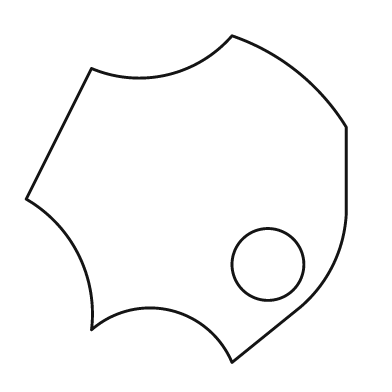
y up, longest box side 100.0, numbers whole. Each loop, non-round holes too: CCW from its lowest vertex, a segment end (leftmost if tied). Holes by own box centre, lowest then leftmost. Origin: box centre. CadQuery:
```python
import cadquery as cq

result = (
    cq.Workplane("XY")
    .moveTo(14.0, -50.0)
    .lineTo(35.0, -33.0)
    .threePointArc((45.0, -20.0), (49.0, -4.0))
    .lineTo(49.0, 22.0)
    .threePointArc((34.0, 39.0), (14.0, 50.0))
    .threePointArc((-6.0, 38.0), (-29.0, 40.0))
    .lineTo(-49.0, 0.0)
    .threePointArc((-33.0, -17.0), (-29.0, -40.0))
    .threePointArc((-5.0, -34.0), (14.0, -50.0))
    .close()
    .moveTo(25.0, -20.0)
    .circle(11.0)
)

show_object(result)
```